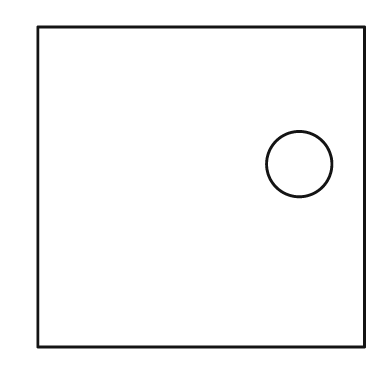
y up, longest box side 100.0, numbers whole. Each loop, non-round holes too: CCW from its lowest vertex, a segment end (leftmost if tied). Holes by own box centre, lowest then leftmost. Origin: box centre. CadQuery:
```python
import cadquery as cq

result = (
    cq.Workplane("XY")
    .moveTo(-50.0, -49.0)
    .lineTo(50.0, -49.0)
    .lineTo(50.0, 49.0)
    .lineTo(-50.0, 49.0)
    .close()
    .moveTo(30.0, 7.0)
    .circle(10.0)
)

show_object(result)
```